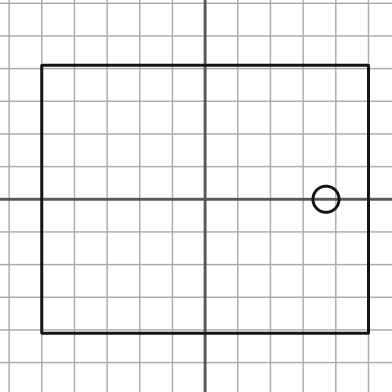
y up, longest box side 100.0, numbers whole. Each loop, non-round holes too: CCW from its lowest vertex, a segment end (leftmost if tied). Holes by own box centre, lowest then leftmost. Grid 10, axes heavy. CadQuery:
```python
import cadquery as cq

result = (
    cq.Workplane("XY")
    .moveTo(-50.0, -41.0)
    .lineTo(50.0, -41.0)
    .lineTo(50.0, 41.0)
    .lineTo(-50.0, 41.0)
    .close()
    .moveTo(37.0, 0.0)
    .circle(4.0)
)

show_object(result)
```